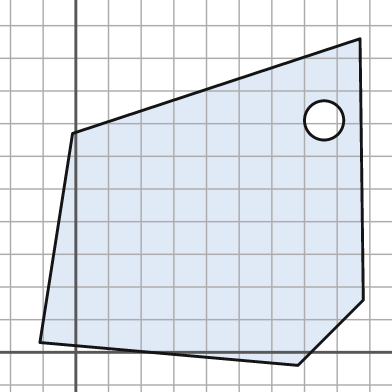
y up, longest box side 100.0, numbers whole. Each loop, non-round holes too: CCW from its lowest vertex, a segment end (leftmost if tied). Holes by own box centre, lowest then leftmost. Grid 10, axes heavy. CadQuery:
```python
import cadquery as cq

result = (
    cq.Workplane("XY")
    .moveTo(68.0, -4.0)
    .lineTo(88.0, 16.0)
    .lineTo(87.0, 96.0)
    .lineTo(-1.0, 67.0)
    .lineTo(-11.0, 3.0)
    .close()
    .moveTo(76.0, 71.0)
    .circle(6.0)
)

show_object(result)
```